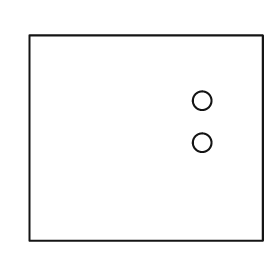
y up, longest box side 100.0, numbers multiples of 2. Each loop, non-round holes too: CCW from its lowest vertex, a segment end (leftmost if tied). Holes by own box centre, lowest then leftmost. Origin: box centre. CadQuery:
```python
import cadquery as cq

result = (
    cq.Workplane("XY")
    .moveTo(-50.0, -44.0)
    .lineTo(50.0, -44.0)
    .lineTo(50.0, 44.0)
    .lineTo(-50.0, 44.0)
    .close()
    .moveTo(24.0, -2.0)
    .circle(4.0)
    .moveTo(24.0, 16.0)
    .circle(4.0)
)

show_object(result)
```